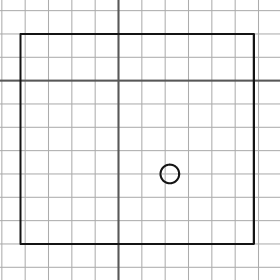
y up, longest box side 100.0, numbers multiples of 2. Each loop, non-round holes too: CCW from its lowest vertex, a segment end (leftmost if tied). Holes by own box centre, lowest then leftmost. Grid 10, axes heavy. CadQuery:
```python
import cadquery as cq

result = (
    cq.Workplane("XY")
    .moveTo(-42.0, -70.0)
    .lineTo(58.0, -70.0)
    .lineTo(58.0, 20.0)
    .lineTo(-42.0, 20.0)
    .close()
    .moveTo(22.0, -40.0)
    .circle(4.0)
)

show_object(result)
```